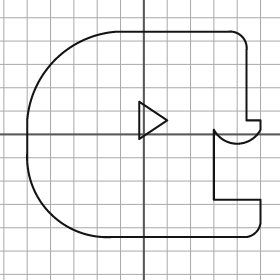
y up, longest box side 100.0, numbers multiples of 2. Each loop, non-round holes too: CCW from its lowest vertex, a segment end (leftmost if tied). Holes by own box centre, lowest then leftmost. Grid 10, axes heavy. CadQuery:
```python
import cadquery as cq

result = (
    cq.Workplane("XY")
    .moveTo(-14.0, -44.0)
    .lineTo(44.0, -44.0)
    .threePointArc((48.0, -42.0), (50.0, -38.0))
    .lineTo(50.0, -28.0)
    .lineTo(30.0, -28.0)
    .lineTo(30.0, 2.0)
    .threePointArc((40.0, -4.0), (50.0, 2.0))
    .lineTo(50.0, 6.0)
    .lineTo(44.0, 6.0)
    .lineTo(44.0, 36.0)
    .threePointArc((42.0, 42.0), (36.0, 44.0))
    .lineTo(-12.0, 44.0)
    .threePointArc((-38.0, 32.0), (-50.0, 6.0))
    .lineTo(-50.0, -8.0)
    .threePointArc((-40.0, -34.0), (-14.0, -44.0))
    .close()
    .moveTo(-2.0, -2.0)
    .lineTo(10.0, 6.0)
    .lineTo(-2.0, 14.0)
    .close()
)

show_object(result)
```